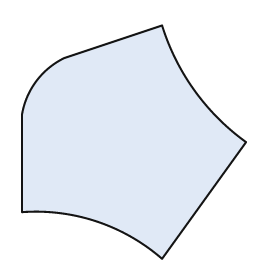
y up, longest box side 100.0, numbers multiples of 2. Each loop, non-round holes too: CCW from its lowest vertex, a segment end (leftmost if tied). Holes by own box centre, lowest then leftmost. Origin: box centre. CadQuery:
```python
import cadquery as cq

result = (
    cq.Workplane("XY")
    .moveTo(12.0, -50.0)
    .lineTo(48.0, 0.0)
    .threePointArc((26.0, 22.0), (12.0, 50.0))
    .lineTo(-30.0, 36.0)
    .threePointArc((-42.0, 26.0), (-48.0, 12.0))
    .lineTo(-48.0, -30.0)
    .threePointArc((-16.0, -34.0), (12.0, -50.0))
    .close()
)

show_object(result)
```